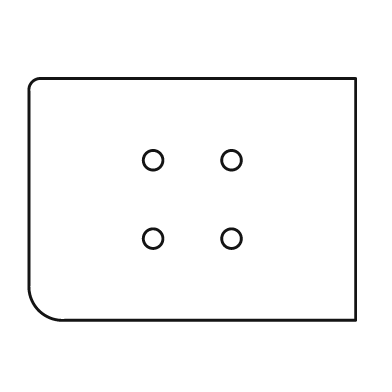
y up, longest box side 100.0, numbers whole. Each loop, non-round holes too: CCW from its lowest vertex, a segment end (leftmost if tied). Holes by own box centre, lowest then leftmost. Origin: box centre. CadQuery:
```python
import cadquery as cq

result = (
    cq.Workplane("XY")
    .moveTo(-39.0, -37.0)
    .lineTo(50.0, -37.0)
    .lineTo(50.0, 37.0)
    .lineTo(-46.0, 37.0)
    .threePointArc((-49.0, 36.0), (-50.0, 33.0))
    .lineTo(-50.0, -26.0)
    .threePointArc((-47.0, -34.0), (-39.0, -37.0))
    .close()
    .moveTo(-12.0, -12.0)
    .circle(3.0)
    .moveTo(12.0, -12.0)
    .circle(3.0)
    .moveTo(-12.0, 12.0)
    .circle(3.0)
    .moveTo(12.0, 12.0)
    .circle(3.0)
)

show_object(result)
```